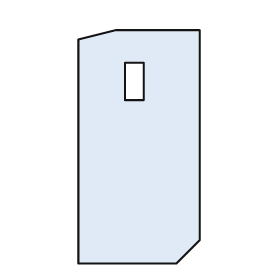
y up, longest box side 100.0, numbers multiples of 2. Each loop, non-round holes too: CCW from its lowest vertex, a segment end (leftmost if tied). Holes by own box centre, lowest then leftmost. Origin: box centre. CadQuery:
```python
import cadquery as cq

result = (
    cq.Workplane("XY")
    .moveTo(-26.0, -50.0)
    .lineTo(16.0, -50.0)
    .lineTo(26.0, -40.0)
    .lineTo(26.0, 50.0)
    .lineTo(-10.0, 50.0)
    .lineTo(-26.0, 46.0)
    .close()
    .moveTo(-6.0, 20.0)
    .lineTo(2.0, 20.0)
    .lineTo(2.0, 36.0)
    .lineTo(-6.0, 36.0)
    .close()
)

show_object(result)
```